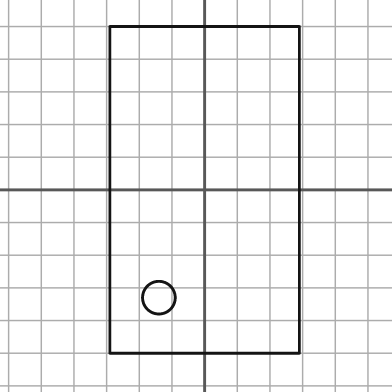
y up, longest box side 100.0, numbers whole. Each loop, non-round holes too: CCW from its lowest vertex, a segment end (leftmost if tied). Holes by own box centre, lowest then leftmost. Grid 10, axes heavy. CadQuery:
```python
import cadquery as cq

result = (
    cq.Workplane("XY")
    .moveTo(-29.0, -50.0)
    .lineTo(29.0, -50.0)
    .lineTo(29.0, 50.0)
    .lineTo(-29.0, 50.0)
    .close()
    .moveTo(-14.0, -33.0)
    .circle(5.0)
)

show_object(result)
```